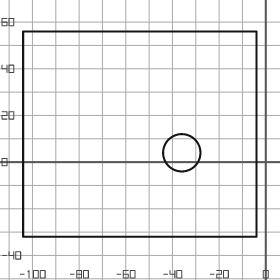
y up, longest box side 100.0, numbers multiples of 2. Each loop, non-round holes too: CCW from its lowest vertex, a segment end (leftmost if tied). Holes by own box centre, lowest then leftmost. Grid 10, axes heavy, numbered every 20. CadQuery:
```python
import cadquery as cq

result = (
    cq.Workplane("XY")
    .moveTo(-104.0, -32.0)
    .lineTo(-4.0, -32.0)
    .lineTo(-4.0, 56.0)
    .lineTo(-104.0, 56.0)
    .close()
    .moveTo(-36.0, 4.0)
    .circle(8.0)
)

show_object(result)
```